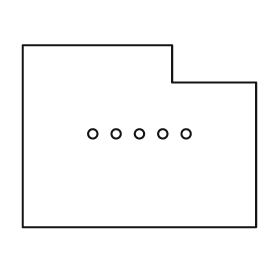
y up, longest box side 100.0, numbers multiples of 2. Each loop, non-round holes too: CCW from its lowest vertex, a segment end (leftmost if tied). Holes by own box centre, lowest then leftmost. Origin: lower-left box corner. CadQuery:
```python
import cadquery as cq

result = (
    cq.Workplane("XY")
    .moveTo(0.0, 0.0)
    .lineTo(100.0, 0.0)
    .lineTo(100.0, 62.0)
    .lineTo(64.0, 62.0)
    .lineTo(64.0, 78.0)
    .lineTo(0.0, 78.0)
    .close()
    .moveTo(30.0, 40.0)
    .circle(2.0)
    .moveTo(40.0, 40.0)
    .circle(2.0)
    .moveTo(50.0, 40.0)
    .circle(2.0)
    .moveTo(60.0, 40.0)
    .circle(2.0)
    .moveTo(70.0, 40.0)
    .circle(2.0)
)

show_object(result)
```